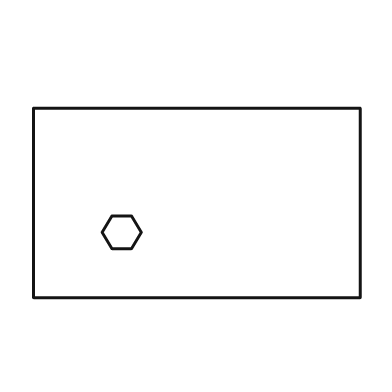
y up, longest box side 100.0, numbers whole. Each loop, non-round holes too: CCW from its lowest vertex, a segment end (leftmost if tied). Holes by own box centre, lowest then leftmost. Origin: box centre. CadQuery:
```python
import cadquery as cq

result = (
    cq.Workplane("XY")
    .moveTo(-50.0, -29.0)
    .lineTo(50.0, -29.0)
    .lineTo(50.0, 29.0)
    .lineTo(-50.0, 29.0)
    .close()
    .moveTo(-26.0, -14.0)
    .lineTo(-20.0, -14.0)
    .lineTo(-17.0, -9.0)
    .lineTo(-20.0, -4.0)
    .lineTo(-26.0, -4.0)
    .lineTo(-29.0, -9.0)
    .close()
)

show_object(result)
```